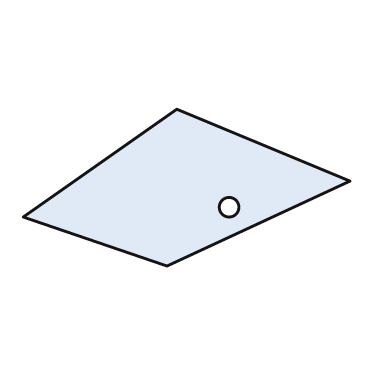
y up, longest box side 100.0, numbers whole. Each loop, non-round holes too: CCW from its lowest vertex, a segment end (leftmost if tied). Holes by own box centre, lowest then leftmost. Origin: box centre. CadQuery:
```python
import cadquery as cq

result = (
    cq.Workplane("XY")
    .moveTo(-6.0, -24.0)
    .lineTo(50.0, 2.0)
    .lineTo(-3.0, 24.0)
    .lineTo(-50.0, -9.0)
    .close()
    .moveTo(13.0, -6.0)
    .circle(3.0)
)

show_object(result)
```